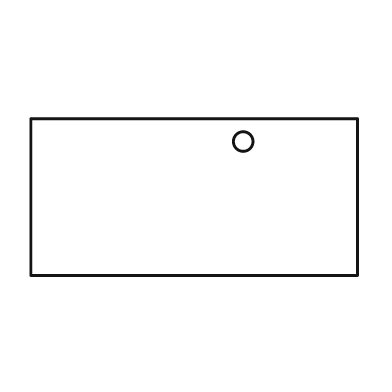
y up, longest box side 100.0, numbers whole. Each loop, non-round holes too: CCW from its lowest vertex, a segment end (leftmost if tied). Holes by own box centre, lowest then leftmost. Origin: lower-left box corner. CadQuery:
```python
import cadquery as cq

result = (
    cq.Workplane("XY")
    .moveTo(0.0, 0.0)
    .lineTo(100.0, 0.0)
    .lineTo(100.0, 48.0)
    .lineTo(0.0, 48.0)
    .close()
    .moveTo(65.0, 41.0)
    .circle(3.0)
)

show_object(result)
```